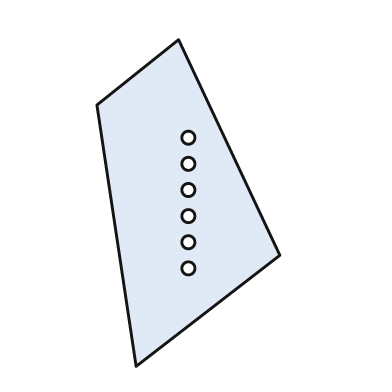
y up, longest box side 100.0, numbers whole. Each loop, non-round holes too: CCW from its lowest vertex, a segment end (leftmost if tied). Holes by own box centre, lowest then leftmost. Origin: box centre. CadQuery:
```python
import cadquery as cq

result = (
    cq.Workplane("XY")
    .moveTo(-16.0, -50.0)
    .lineTo(28.0, -16.0)
    .lineTo(-3.0, 50.0)
    .lineTo(-28.0, 30.0)
    .close()
    .moveTo(0.0, -20.0)
    .circle(2.0)
    .moveTo(0.0, -12.0)
    .circle(2.0)
    .moveTo(0.0, -4.0)
    .circle(2.0)
    .moveTo(0.0, 4.0)
    .circle(2.0)
    .moveTo(0.0, 12.0)
    .circle(2.0)
    .moveTo(0.0, 20.0)
    .circle(2.0)
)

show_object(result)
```